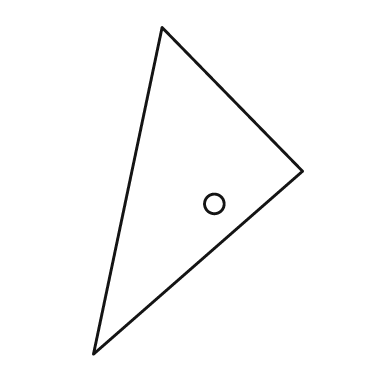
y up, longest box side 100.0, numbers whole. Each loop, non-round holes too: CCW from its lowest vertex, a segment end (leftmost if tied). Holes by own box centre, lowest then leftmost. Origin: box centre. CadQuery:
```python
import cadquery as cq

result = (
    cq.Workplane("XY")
    .moveTo(-32.0, -50.0)
    .lineTo(32.0, 6.0)
    .lineTo(-11.0, 50.0)
    .close()
    .moveTo(5.0, -4.0)
    .circle(3.0)
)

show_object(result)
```